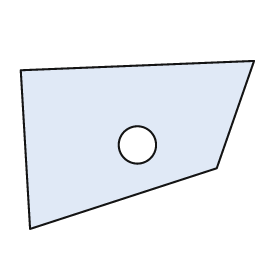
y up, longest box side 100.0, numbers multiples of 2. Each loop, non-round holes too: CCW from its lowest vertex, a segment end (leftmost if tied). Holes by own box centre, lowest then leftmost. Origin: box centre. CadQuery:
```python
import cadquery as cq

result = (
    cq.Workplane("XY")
    .moveTo(-46.0, -36.0)
    .lineTo(34.0, -10.0)
    .lineTo(50.0, 36.0)
    .lineTo(-50.0, 32.0)
    .close()
    .moveTo(0.0, 0.0)
    .circle(8.0)
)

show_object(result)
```